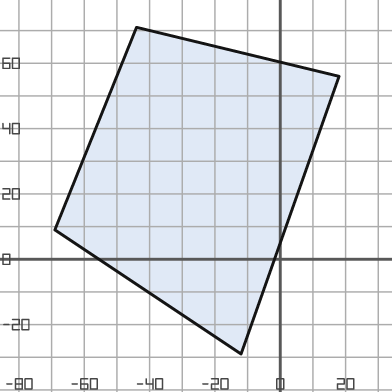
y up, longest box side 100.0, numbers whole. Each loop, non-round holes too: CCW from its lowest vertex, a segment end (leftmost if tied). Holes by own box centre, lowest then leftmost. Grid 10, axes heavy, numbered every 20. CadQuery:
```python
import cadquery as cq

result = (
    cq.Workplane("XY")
    .moveTo(-12.0, -29.0)
    .lineTo(18.0, 56.0)
    .lineTo(-44.0, 71.0)
    .lineTo(-69.0, 9.0)
    .close()
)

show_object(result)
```